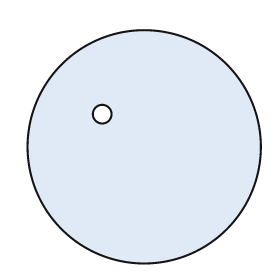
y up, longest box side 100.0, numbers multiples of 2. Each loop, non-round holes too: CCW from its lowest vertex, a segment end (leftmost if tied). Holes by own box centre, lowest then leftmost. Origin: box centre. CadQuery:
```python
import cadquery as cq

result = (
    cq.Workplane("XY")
    .moveTo(0.0, 0.0)
    .circle(50.0)
    .moveTo(-18.0, 14.0)
    .circle(4.0)
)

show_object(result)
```